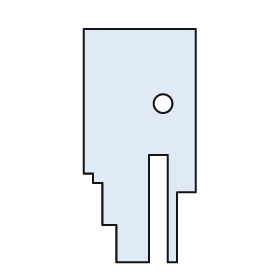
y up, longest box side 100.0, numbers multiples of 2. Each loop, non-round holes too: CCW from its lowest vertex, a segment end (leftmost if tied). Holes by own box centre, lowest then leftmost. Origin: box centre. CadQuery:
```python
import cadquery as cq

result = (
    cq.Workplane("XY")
    .moveTo(-10.0, -50.0)
    .lineTo(4.0, -50.0)
    .lineTo(4.0, -4.0)
    .lineTo(12.0, -4.0)
    .lineTo(12.0, -50.0)
    .lineTo(16.0, -50.0)
    .lineTo(16.0, -20.0)
    .lineTo(24.0, -20.0)
    .lineTo(24.0, 50.0)
    .lineTo(-24.0, 50.0)
    .lineTo(-24.0, -12.0)
    .lineTo(-20.0, -12.0)
    .lineTo(-20.0, -16.0)
    .lineTo(-16.0, -16.0)
    .lineTo(-16.0, -34.0)
    .lineTo(-10.0, -34.0)
    .close()
    .moveTo(10.0, 18.0)
    .circle(4.0)
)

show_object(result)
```